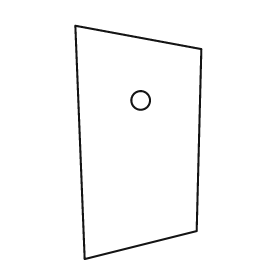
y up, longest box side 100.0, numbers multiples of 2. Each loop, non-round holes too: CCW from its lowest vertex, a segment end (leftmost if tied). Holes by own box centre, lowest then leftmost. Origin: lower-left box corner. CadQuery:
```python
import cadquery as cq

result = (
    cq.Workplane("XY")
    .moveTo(4.0, 0.0)
    .lineTo(52.0, 12.0)
    .lineTo(54.0, 90.0)
    .lineTo(0.0, 100.0)
    .close()
    .moveTo(28.0, 68.0)
    .circle(4.0)
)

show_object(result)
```